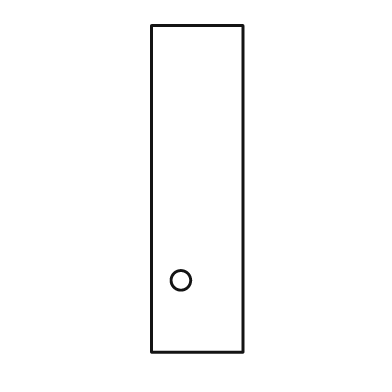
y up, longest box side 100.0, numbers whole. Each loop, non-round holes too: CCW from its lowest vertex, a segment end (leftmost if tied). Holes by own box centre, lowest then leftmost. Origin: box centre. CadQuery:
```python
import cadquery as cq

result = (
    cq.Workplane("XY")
    .moveTo(-14.0, -50.0)
    .lineTo(14.0, -50.0)
    .lineTo(14.0, 50.0)
    .lineTo(-14.0, 50.0)
    .close()
    .moveTo(-5.0, -28.0)
    .circle(3.0)
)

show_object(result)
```